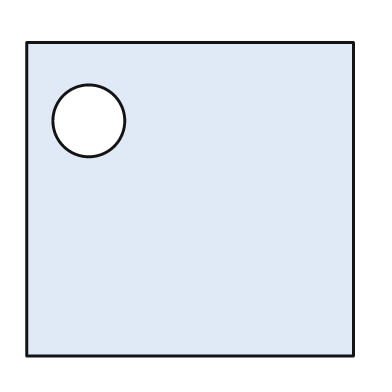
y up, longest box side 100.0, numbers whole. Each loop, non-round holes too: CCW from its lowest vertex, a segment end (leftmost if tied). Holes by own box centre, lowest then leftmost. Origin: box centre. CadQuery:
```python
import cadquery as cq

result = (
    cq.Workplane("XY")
    .moveTo(-50.0, -48.0)
    .lineTo(50.0, -48.0)
    .lineTo(50.0, 48.0)
    .lineTo(-50.0, 48.0)
    .close()
    .moveTo(-31.0, 24.0)
    .circle(11.0)
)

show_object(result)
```